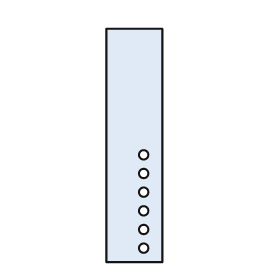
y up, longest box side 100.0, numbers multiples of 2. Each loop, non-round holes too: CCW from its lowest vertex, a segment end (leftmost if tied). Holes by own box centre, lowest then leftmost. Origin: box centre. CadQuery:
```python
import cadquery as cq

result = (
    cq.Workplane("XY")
    .moveTo(-12.0, -50.0)
    .lineTo(12.0, -50.0)
    .lineTo(12.0, 50.0)
    .lineTo(-12.0, 50.0)
    .close()
    .moveTo(4.0, -44.0)
    .circle(2.0)
    .moveTo(4.0, -36.0)
    .circle(2.0)
    .moveTo(4.0, -28.0)
    .circle(2.0)
    .moveTo(4.0, -20.0)
    .circle(2.0)
    .moveTo(4.0, -12.0)
    .circle(2.0)
    .moveTo(4.0, -4.0)
    .circle(2.0)
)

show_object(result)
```